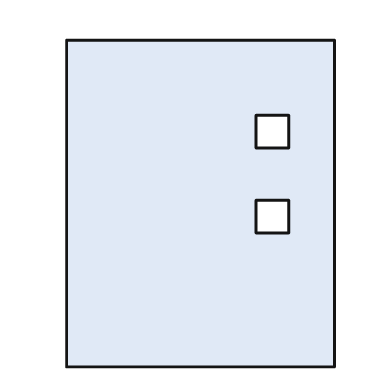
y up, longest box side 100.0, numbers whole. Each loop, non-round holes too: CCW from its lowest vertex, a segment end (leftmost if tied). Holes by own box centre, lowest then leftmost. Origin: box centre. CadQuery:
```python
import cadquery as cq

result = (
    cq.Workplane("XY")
    .moveTo(-41.0, -50.0)
    .lineTo(41.0, -50.0)
    .lineTo(41.0, 50.0)
    .lineTo(-41.0, 50.0)
    .close()
    .moveTo(17.0, -9.0)
    .lineTo(27.0, -9.0)
    .lineTo(27.0, 1.0)
    .lineTo(17.0, 1.0)
    .close()
    .moveTo(17.0, 17.0)
    .lineTo(27.0, 17.0)
    .lineTo(27.0, 27.0)
    .lineTo(17.0, 27.0)
    .close()
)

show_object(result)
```